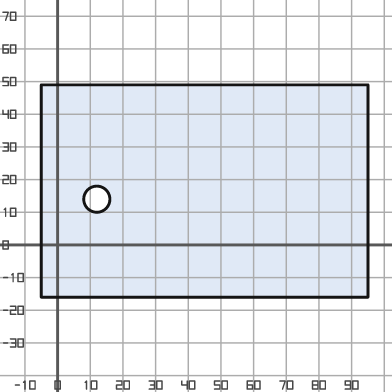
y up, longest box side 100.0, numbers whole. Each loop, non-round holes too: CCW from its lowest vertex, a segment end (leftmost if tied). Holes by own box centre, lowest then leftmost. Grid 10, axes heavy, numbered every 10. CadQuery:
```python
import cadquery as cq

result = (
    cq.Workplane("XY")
    .moveTo(-5.0, -16.0)
    .lineTo(95.0, -16.0)
    .lineTo(95.0, 49.0)
    .lineTo(-5.0, 49.0)
    .close()
    .moveTo(12.0, 14.0)
    .circle(4.0)
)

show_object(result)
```